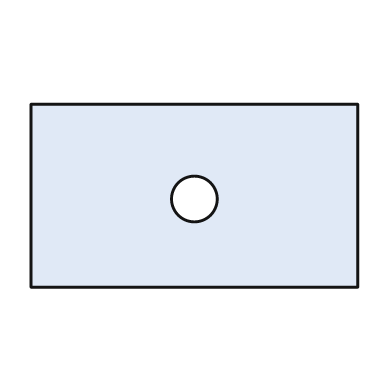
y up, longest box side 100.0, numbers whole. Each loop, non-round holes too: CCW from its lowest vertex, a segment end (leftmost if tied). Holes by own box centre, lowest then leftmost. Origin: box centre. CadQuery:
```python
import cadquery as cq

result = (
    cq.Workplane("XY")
    .moveTo(-50.0, -28.0)
    .lineTo(50.0, -28.0)
    .lineTo(50.0, 28.0)
    .lineTo(-50.0, 28.0)
    .close()
    .moveTo(0.0, -1.0)
    .circle(7.0)
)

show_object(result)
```